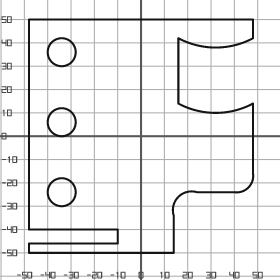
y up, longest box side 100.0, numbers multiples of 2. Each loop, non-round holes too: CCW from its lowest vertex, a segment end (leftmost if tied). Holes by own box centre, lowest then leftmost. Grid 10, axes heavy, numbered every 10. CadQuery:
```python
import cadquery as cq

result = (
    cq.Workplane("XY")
    .moveTo(-48.0, -50.0)
    .lineTo(14.0, -50.0)
    .lineTo(14.0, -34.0)
    .threePointArc((16.0, -26.0), (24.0, -24.0))
    .lineTo(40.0, -24.0)
    .threePointArc((46.0, -22.0), (48.0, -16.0))
    .lineTo(48.0, 14.0)
    .threePointArc((32.0, 10.0), (16.0, 14.0))
    .lineTo(16.0, 42.0)
    .threePointArc((32.0, 38.0), (48.0, 42.0))
    .lineTo(48.0, 50.0)
    .lineTo(-48.0, 50.0)
    .lineTo(-48.0, -40.0)
    .lineTo(-10.0, -40.0)
    .lineTo(-10.0, -46.0)
    .lineTo(-48.0, -46.0)
    .close()
    .moveTo(-34.0, -24.0)
    .circle(6.0)
    .moveTo(-34.0, 6.0)
    .circle(6.0)
    .moveTo(-34.0, 36.0)
    .circle(6.0)
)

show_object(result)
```